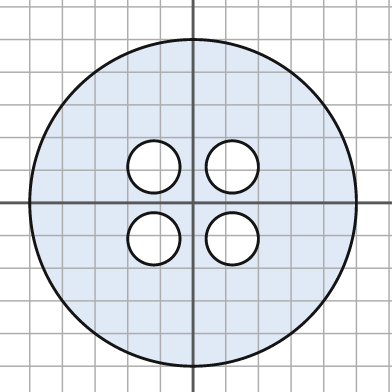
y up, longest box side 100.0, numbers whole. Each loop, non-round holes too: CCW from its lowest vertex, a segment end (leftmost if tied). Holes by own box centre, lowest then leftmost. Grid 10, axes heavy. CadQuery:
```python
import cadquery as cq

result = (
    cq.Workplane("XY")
    .moveTo(0.0, 0.0)
    .circle(50.0)
    .moveTo(-12.0, -11.0)
    .circle(8.0)
    .moveTo(12.0, -11.0)
    .circle(8.0)
    .moveTo(-12.0, 11.0)
    .circle(8.0)
    .moveTo(12.0, 11.0)
    .circle(8.0)
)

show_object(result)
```